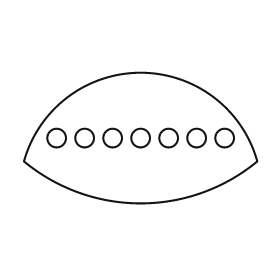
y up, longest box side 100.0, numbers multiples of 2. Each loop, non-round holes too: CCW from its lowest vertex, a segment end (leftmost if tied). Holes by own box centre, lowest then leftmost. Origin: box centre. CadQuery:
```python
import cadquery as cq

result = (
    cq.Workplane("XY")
    .moveTo(-50.0, -10.0)
    .threePointArc((0.0, -28.0), (50.0, -10.0))
    .threePointArc((0.0, 28.0), (-50.0, -10.0))
    .close()
    .moveTo(-36.0, 0.0)
    .circle(4.0)
    .moveTo(-24.0, 0.0)
    .circle(4.0)
    .moveTo(-12.0, 0.0)
    .circle(4.0)
    .moveTo(0.0, 0.0)
    .circle(4.0)
    .moveTo(12.0, 0.0)
    .circle(4.0)
    .moveTo(24.0, 0.0)
    .circle(4.0)
    .moveTo(36.0, 0.0)
    .circle(4.0)
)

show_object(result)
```